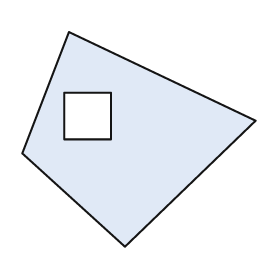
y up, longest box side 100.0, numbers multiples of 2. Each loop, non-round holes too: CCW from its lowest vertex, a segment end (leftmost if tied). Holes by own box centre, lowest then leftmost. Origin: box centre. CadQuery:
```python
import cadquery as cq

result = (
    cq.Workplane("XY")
    .moveTo(-6.0, -46.0)
    .lineTo(50.0, 8.0)
    .lineTo(-30.0, 46.0)
    .lineTo(-50.0, -6.0)
    .close()
    .moveTo(-32.0, 0.0)
    .lineTo(-12.0, 0.0)
    .lineTo(-12.0, 20.0)
    .lineTo(-32.0, 20.0)
    .close()
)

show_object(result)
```